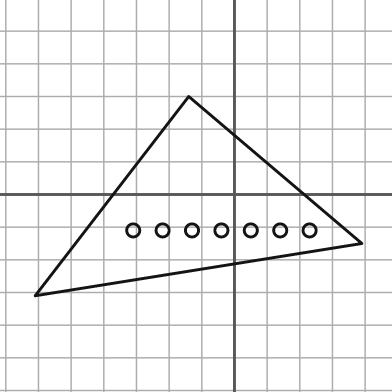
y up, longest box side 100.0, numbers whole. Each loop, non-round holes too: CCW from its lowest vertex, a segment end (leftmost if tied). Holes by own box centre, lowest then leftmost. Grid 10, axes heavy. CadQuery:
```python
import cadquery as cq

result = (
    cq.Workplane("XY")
    .moveTo(-61.0, -31.0)
    .lineTo(39.0, -15.0)
    .lineTo(-14.0, 30.0)
    .close()
    .moveTo(-31.0, -11.0)
    .circle(2.0)
    .moveTo(-22.0, -11.0)
    .circle(2.0)
    .moveTo(-13.0, -11.0)
    .circle(2.0)
    .moveTo(-4.0, -11.0)
    .circle(2.0)
    .moveTo(5.0, -11.0)
    .circle(2.0)
    .moveTo(14.0, -11.0)
    .circle(2.0)
    .moveTo(23.0, -11.0)
    .circle(2.0)
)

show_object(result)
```